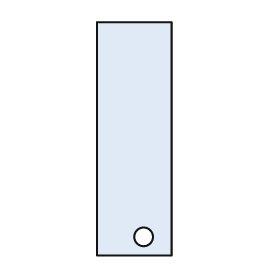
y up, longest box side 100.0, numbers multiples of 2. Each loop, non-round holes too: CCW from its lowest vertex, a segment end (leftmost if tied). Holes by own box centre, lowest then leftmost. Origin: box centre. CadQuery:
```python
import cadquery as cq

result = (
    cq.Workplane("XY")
    .moveTo(-16.0, -50.0)
    .lineTo(16.0, -50.0)
    .lineTo(16.0, 50.0)
    .lineTo(-16.0, 50.0)
    .close()
    .moveTo(4.0, -42.0)
    .circle(4.0)
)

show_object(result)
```